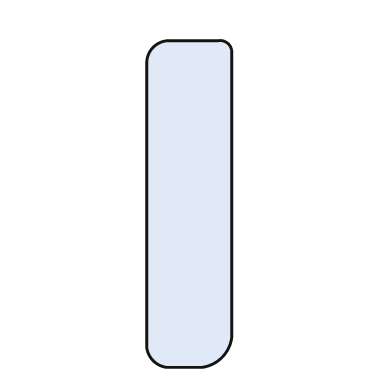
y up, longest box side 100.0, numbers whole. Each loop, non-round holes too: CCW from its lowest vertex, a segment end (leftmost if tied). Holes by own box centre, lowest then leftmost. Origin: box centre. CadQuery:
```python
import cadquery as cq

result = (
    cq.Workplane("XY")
    .moveTo(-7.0, -50.0)
    .lineTo(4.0, -50.0)
    .threePointArc((10.0, -47.0), (13.0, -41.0))
    .lineTo(13.0, 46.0)
    .threePointArc((12.0, 49.0), (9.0, 50.0))
    .lineTo(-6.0, 50.0)
    .threePointArc((-11.0, 48.0), (-13.0, 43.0))
    .lineTo(-13.0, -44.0)
    .threePointArc((-11.0, -48.0), (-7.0, -50.0))
    .close()
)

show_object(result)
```